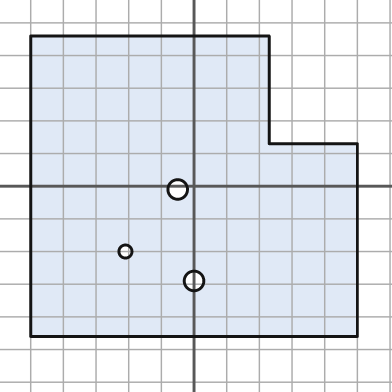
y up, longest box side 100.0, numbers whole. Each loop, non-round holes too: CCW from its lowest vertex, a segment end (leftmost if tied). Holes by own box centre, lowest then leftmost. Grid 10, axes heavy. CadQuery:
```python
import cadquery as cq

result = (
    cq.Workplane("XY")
    .moveTo(-50.0, -46.0)
    .lineTo(50.0, -46.0)
    .lineTo(50.0, 13.0)
    .lineTo(23.0, 13.0)
    .lineTo(23.0, 46.0)
    .lineTo(-50.0, 46.0)
    .close()
    .moveTo(0.0, -29.0)
    .circle(3.0)
    .moveTo(-21.0, -20.0)
    .circle(2.0)
    .moveTo(-5.0, -1.0)
    .circle(3.0)
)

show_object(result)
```